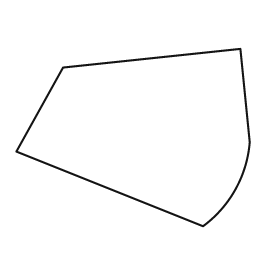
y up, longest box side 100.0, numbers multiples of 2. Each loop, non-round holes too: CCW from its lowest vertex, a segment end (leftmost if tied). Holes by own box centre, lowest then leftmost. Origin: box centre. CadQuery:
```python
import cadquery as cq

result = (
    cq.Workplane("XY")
    .moveTo(30.0, -38.0)
    .threePointArc((44.0, -22.0), (50.0, -2.0))
    .lineTo(46.0, 38.0)
    .lineTo(-30.0, 30.0)
    .lineTo(-50.0, -6.0)
    .close()
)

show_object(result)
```